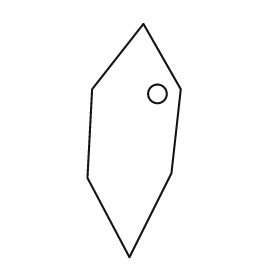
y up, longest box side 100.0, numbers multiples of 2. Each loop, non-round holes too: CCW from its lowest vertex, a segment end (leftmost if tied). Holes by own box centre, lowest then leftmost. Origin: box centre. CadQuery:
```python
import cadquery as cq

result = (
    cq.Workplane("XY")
    .moveTo(-2.0, -50.0)
    .lineTo(16.0, -14.0)
    .lineTo(20.0, 22.0)
    .lineTo(4.0, 50.0)
    .lineTo(-18.0, 22.0)
    .lineTo(-20.0, -16.0)
    .close()
    .moveTo(10.0, 20.0)
    .circle(4.0)
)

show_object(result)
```